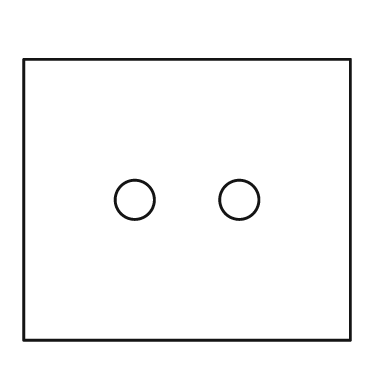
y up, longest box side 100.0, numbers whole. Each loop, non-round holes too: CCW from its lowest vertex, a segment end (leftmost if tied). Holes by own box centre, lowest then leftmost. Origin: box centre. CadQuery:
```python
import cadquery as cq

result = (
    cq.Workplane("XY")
    .moveTo(-50.0, -43.0)
    .lineTo(50.0, -43.0)
    .lineTo(50.0, 43.0)
    .lineTo(-50.0, 43.0)
    .close()
    .moveTo(-16.0, 0.0)
    .circle(6.0)
    .moveTo(16.0, 0.0)
    .circle(6.0)
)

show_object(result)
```